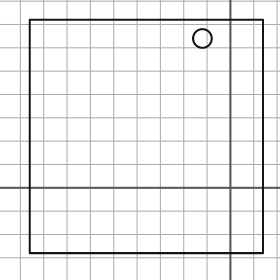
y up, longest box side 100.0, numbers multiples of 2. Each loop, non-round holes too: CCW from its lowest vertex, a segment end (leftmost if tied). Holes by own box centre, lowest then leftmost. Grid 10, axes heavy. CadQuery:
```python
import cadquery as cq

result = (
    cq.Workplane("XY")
    .moveTo(-86.0, -28.0)
    .lineTo(14.0, -28.0)
    .lineTo(14.0, 72.0)
    .lineTo(-86.0, 72.0)
    .close()
    .moveTo(-12.0, 64.0)
    .circle(4.0)
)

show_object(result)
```